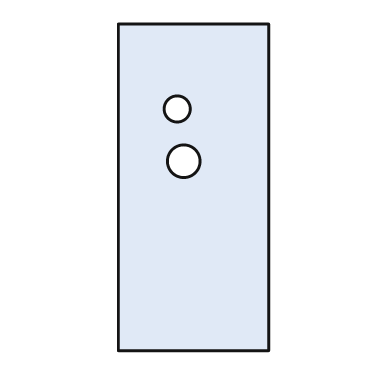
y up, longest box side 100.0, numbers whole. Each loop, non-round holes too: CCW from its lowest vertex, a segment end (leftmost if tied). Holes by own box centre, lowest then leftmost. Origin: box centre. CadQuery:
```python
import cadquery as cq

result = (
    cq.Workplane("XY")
    .moveTo(-23.0, -50.0)
    .lineTo(23.0, -50.0)
    .lineTo(23.0, 50.0)
    .lineTo(-23.0, 50.0)
    .close()
    .moveTo(-3.0, 8.0)
    .circle(5.0)
    .moveTo(-5.0, 24.0)
    .circle(4.0)
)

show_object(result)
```